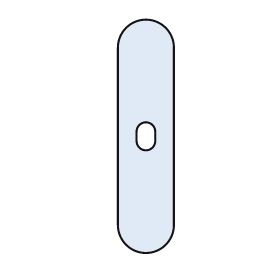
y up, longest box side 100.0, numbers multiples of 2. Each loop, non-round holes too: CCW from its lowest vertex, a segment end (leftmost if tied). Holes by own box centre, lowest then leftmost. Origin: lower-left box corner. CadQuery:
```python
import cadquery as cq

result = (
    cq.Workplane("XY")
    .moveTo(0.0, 12.0)
    .threePointArc((12.0, 0.0), (24.0, 12.0))
    .lineTo(24.0, 88.0)
    .threePointArc((12.0, 100.0), (0.0, 88.0))
    .close()
    .moveTo(8.0, 48.0)
    .threePointArc((12.0, 44.0), (16.0, 48.0))
    .lineTo(16.0, 52.0)
    .threePointArc((12.0, 56.0), (8.0, 52.0))
    .close()
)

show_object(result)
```